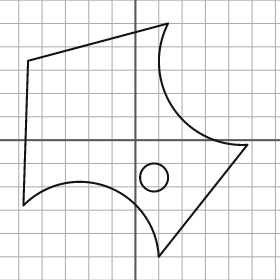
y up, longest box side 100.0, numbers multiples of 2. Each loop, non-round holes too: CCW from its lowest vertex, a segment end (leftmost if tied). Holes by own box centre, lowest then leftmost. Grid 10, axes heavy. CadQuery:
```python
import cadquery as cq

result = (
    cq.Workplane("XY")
    .moveTo(10.0, -50.0)
    .lineTo(48.0, -2.0)
    .threePointArc((16.0, 14.0), (14.0, 50.0))
    .lineTo(-46.0, 34.0)
    .lineTo(-48.0, -28.0)
    .threePointArc((-12.0, -20.0), (10.0, -50.0))
    .close()
    .moveTo(8.0, -16.0)
    .circle(6.0)
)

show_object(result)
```